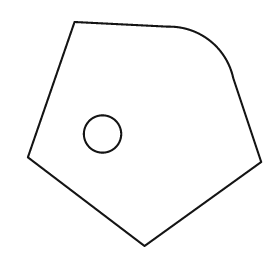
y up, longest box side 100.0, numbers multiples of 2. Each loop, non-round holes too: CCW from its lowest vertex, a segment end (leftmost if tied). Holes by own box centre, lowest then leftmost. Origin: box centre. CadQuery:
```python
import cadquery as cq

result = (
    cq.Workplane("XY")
    .moveTo(0.0, -48.0)
    .lineTo(50.0, -12.0)
    .lineTo(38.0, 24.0)
    .threePointArc((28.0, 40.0), (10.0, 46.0))
    .lineTo(-30.0, 48.0)
    .lineTo(-50.0, -10.0)
    .close()
    .moveTo(-18.0, 0.0)
    .circle(8.0)
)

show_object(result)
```